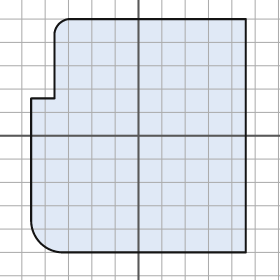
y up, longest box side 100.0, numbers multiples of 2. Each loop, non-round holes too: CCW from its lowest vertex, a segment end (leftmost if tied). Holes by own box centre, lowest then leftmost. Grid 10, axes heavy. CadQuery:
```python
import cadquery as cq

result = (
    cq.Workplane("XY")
    .moveTo(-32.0, -50.0)
    .lineTo(46.0, -50.0)
    .lineTo(46.0, 50.0)
    .lineTo(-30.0, 50.0)
    .threePointArc((-34.0, 48.0), (-36.0, 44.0))
    .lineTo(-36.0, 16.0)
    .lineTo(-46.0, 16.0)
    .lineTo(-46.0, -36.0)
    .threePointArc((-42.0, -46.0), (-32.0, -50.0))
    .close()
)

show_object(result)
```